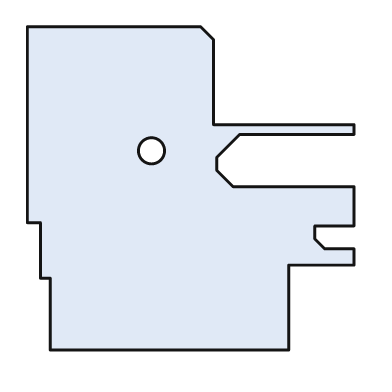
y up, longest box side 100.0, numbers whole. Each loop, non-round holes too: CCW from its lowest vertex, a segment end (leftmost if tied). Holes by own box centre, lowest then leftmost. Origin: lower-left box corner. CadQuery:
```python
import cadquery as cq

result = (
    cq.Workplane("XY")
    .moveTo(7.0, 0.0)
    .lineTo(80.0, 0.0)
    .lineTo(80.0, 26.0)
    .lineTo(100.0, 26.0)
    .lineTo(100.0, 31.0)
    .lineTo(91.0, 31.0)
    .lineTo(88.0, 34.0)
    .lineTo(88.0, 38.0)
    .lineTo(100.0, 38.0)
    .lineTo(100.0, 50.0)
    .lineTo(63.0, 50.0)
    .lineTo(58.0, 55.0)
    .lineTo(58.0, 59.0)
    .lineTo(65.0, 66.0)
    .lineTo(100.0, 66.0)
    .lineTo(100.0, 69.0)
    .lineTo(57.0, 69.0)
    .lineTo(57.0, 95.0)
    .lineTo(53.0, 99.0)
    .lineTo(0.0, 99.0)
    .lineTo(0.0, 39.0)
    .lineTo(4.0, 39.0)
    .lineTo(4.0, 22.0)
    .lineTo(7.0, 22.0)
    .close()
    .moveTo(38.0, 61.0)
    .circle(4.0)
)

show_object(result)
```